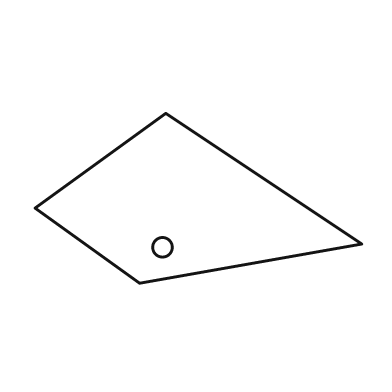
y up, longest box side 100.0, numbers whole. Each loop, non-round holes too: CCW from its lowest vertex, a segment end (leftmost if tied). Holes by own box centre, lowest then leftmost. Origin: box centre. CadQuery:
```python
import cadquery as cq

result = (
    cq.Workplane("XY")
    .moveTo(-18.0, -26.0)
    .lineTo(50.0, -14.0)
    .lineTo(-10.0, 26.0)
    .lineTo(-50.0, -3.0)
    .close()
    .moveTo(-11.0, -15.0)
    .circle(3.0)
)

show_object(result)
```